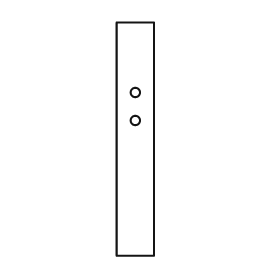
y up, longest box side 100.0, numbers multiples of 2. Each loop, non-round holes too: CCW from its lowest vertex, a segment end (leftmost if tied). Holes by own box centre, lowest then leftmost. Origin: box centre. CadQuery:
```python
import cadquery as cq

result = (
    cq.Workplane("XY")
    .moveTo(-8.0, -50.0)
    .lineTo(8.0, -50.0)
    .lineTo(8.0, 50.0)
    .lineTo(-8.0, 50.0)
    .close()
    .moveTo(0.0, 8.0)
    .circle(2.0)
    .moveTo(0.0, 20.0)
    .circle(2.0)
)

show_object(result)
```